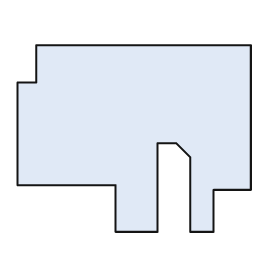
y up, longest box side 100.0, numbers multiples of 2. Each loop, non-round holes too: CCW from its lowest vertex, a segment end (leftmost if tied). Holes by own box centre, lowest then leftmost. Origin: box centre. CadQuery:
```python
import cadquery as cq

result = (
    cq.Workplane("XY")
    .moveTo(-8.0, -40.0)
    .lineTo(10.0, -40.0)
    .lineTo(10.0, -2.0)
    .lineTo(18.0, -2.0)
    .lineTo(24.0, -8.0)
    .lineTo(24.0, -40.0)
    .lineTo(34.0, -40.0)
    .lineTo(34.0, -22.0)
    .lineTo(50.0, -22.0)
    .lineTo(50.0, 40.0)
    .lineTo(-42.0, 40.0)
    .lineTo(-42.0, 24.0)
    .lineTo(-50.0, 24.0)
    .lineTo(-50.0, -20.0)
    .lineTo(-8.0, -20.0)
    .close()
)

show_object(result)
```